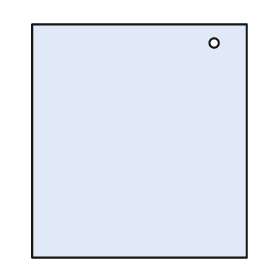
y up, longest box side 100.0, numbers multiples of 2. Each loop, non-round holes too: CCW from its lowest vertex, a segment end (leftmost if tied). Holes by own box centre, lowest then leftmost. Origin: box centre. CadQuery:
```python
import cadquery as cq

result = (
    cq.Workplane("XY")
    .moveTo(-46.0, -50.0)
    .lineTo(46.0, -50.0)
    .lineTo(46.0, 50.0)
    .lineTo(-46.0, 50.0)
    .close()
    .moveTo(32.0, 42.0)
    .circle(2.0)
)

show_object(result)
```